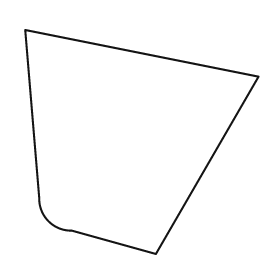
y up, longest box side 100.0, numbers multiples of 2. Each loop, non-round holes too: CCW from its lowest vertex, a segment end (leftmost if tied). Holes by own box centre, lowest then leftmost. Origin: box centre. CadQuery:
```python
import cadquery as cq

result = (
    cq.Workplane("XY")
    .moveTo(6.0, -48.0)
    .lineTo(50.0, 28.0)
    .lineTo(-50.0, 48.0)
    .lineTo(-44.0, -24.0)
    .threePointArc((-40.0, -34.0), (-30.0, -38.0))
    .close()
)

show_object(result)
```